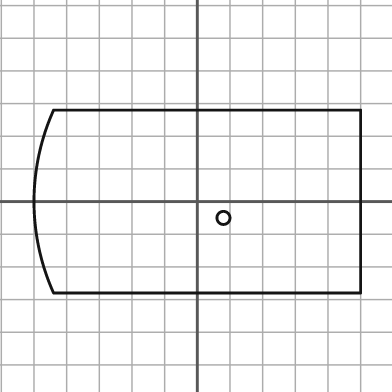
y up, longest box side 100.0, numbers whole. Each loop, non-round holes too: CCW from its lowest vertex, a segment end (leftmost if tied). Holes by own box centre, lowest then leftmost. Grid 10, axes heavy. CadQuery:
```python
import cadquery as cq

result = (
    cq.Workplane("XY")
    .moveTo(-44.0, -28.0)
    .lineTo(50.0, -28.0)
    .lineTo(50.0, 28.0)
    .lineTo(-44.0, 28.0)
    .threePointArc((-50.0, 0.0), (-44.0, -28.0))
    .close()
    .moveTo(8.0, -5.0)
    .circle(2.0)
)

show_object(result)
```